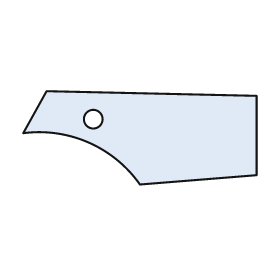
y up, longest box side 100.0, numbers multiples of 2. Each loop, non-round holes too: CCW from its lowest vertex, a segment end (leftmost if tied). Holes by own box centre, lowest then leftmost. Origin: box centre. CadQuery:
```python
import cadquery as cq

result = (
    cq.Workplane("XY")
    .moveTo(0.0, -20.0)
    .lineTo(50.0, -16.0)
    .lineTo(50.0, 18.0)
    .lineTo(-40.0, 20.0)
    .lineTo(-50.0, 2.0)
    .threePointArc((-22.0, -2.0), (0.0, -20.0))
    .close()
    .moveTo(-20.0, 8.0)
    .circle(4.0)
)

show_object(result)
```